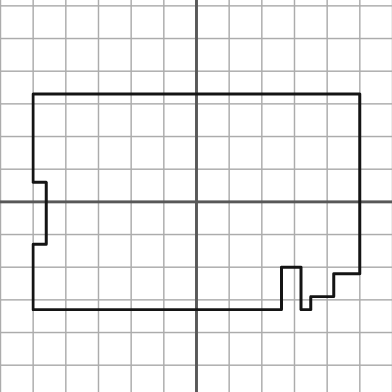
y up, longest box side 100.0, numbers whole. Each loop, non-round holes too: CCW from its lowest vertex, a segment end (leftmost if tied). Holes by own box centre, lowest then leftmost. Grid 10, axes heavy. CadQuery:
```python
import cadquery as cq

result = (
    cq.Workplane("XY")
    .moveTo(-50.0, -33.0)
    .lineTo(26.0, -33.0)
    .lineTo(26.0, -20.0)
    .lineTo(32.0, -20.0)
    .lineTo(32.0, -33.0)
    .lineTo(35.0, -33.0)
    .lineTo(35.0, -29.0)
    .lineTo(42.0, -29.0)
    .lineTo(42.0, -22.0)
    .lineTo(50.0, -22.0)
    .lineTo(50.0, 33.0)
    .lineTo(-50.0, 33.0)
    .lineTo(-50.0, 6.0)
    .lineTo(-46.0, 6.0)
    .lineTo(-46.0, -13.0)
    .lineTo(-50.0, -13.0)
    .close()
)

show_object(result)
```